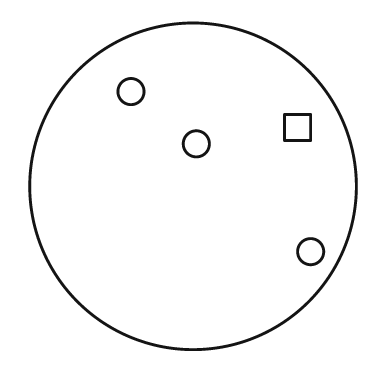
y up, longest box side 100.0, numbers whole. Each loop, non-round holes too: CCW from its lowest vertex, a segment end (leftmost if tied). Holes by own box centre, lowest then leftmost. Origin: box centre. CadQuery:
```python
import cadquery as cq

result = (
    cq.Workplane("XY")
    .moveTo(0.0, 0.0)
    .circle(50.0)
    .moveTo(36.0, -20.0)
    .circle(4.0)
    .moveTo(1.0, 13.0)
    .circle(4.0)
    .moveTo(28.0, 14.0)
    .lineTo(36.0, 14.0)
    .lineTo(36.0, 22.0)
    .lineTo(28.0, 22.0)
    .close()
    .moveTo(-19.0, 29.0)
    .circle(4.0)
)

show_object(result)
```